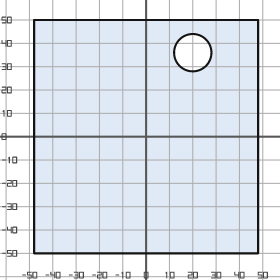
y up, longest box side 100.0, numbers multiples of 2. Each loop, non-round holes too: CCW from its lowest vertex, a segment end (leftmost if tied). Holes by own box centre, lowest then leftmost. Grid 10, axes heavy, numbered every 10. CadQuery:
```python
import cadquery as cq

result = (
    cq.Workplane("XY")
    .moveTo(-48.0, -50.0)
    .lineTo(48.0, -50.0)
    .lineTo(48.0, 50.0)
    .lineTo(-48.0, 50.0)
    .close()
    .moveTo(20.0, 36.0)
    .circle(8.0)
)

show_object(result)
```